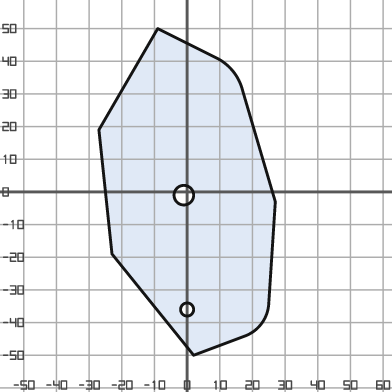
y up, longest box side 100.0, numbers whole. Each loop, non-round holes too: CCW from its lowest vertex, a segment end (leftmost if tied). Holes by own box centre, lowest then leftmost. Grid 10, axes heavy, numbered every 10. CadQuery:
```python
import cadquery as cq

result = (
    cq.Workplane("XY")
    .moveTo(2.0, -50.0)
    .lineTo(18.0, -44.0)
    .threePointArc((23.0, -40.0), (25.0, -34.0))
    .lineTo(27.0, -3.0)
    .lineTo(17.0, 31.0)
    .threePointArc((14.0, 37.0), (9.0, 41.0))
    .lineTo(-9.0, 50.0)
    .lineTo(-27.0, 19.0)
    .lineTo(-23.0, -19.0)
    .close()
    .moveTo(0.0, -36.0)
    .circle(2.0)
    .moveTo(-1.0, -1.0)
    .circle(3.0)
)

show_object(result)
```